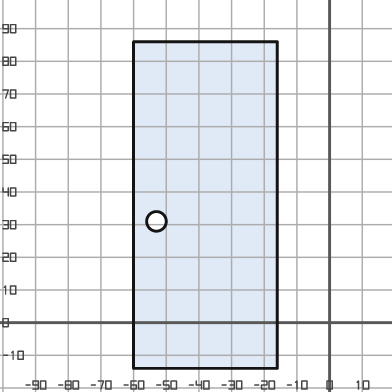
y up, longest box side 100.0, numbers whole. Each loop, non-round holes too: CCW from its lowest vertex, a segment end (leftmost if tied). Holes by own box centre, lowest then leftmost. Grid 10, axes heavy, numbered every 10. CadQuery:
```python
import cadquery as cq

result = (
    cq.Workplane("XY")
    .moveTo(-60.0, -14.0)
    .lineTo(-16.0, -14.0)
    .lineTo(-16.0, 86.0)
    .lineTo(-60.0, 86.0)
    .close()
    .moveTo(-53.0, 31.0)
    .circle(3.0)
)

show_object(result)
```